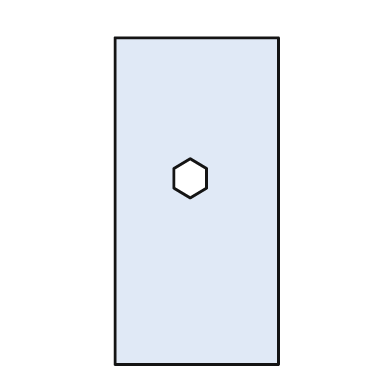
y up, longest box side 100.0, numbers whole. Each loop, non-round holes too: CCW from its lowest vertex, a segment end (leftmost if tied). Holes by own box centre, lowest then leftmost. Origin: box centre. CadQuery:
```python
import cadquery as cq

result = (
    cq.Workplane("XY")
    .moveTo(-25.0, -50.0)
    .lineTo(25.0, -50.0)
    .lineTo(25.0, 50.0)
    .lineTo(-25.0, 50.0)
    .close()
    .moveTo(-2.0, 1.0)
    .lineTo(3.0, 4.0)
    .lineTo(3.0, 10.0)
    .lineTo(-2.0, 13.0)
    .lineTo(-7.0, 10.0)
    .lineTo(-7.0, 4.0)
    .close()
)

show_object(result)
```